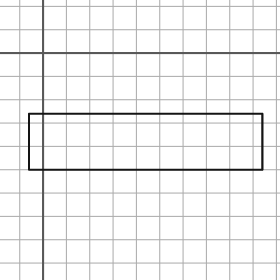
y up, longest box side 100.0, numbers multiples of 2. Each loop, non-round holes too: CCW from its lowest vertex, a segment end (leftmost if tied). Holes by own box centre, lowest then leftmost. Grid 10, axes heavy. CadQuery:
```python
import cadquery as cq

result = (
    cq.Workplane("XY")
    .moveTo(-6.0, -50.0)
    .lineTo(94.0, -50.0)
    .lineTo(94.0, -26.0)
    .lineTo(-6.0, -26.0)
    .close()
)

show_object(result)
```